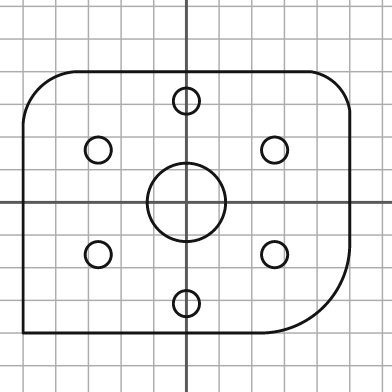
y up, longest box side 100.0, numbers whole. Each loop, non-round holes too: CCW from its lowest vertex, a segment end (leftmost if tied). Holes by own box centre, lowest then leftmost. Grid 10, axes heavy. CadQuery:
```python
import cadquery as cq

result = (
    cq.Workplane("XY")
    .moveTo(-50.0, -40.0)
    .lineTo(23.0, -40.0)
    .threePointArc((42.0, -32.0), (50.0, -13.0))
    .lineTo(50.0, 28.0)
    .threePointArc((46.0, 36.0), (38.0, 40.0))
    .lineTo(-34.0, 40.0)
    .threePointArc((-45.0, 35.0), (-50.0, 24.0))
    .close()
    .moveTo(0.0, -31.0)
    .circle(4.0)
    .moveTo(-27.0, -16.0)
    .circle(4.0)
    .moveTo(27.0, -16.0)
    .circle(4.0)
    .moveTo(0.0, 0.0)
    .circle(12.0)
    .moveTo(-27.0, 16.0)
    .circle(4.0)
    .moveTo(27.0, 16.0)
    .circle(4.0)
    .moveTo(0.0, 31.0)
    .circle(4.0)
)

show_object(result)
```